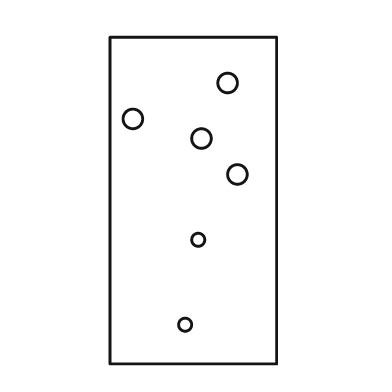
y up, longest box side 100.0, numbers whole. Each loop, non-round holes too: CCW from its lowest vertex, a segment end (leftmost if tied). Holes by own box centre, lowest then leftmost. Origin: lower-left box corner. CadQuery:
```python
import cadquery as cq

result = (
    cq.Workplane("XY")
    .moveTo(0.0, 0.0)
    .lineTo(51.0, 0.0)
    .lineTo(51.0, 100.0)
    .lineTo(0.0, 100.0)
    .close()
    .moveTo(23.0, 12.0)
    .circle(2.0)
    .moveTo(27.0, 38.0)
    .circle(2.0)
    .moveTo(39.0, 58.0)
    .circle(3.0)
    .moveTo(28.0, 69.0)
    .circle(3.0)
    .moveTo(7.0, 75.0)
    .circle(3.0)
    .moveTo(36.0, 86.0)
    .circle(3.0)
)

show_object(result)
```